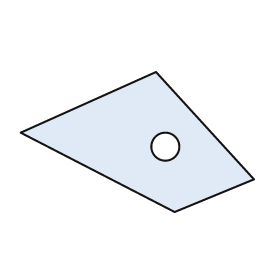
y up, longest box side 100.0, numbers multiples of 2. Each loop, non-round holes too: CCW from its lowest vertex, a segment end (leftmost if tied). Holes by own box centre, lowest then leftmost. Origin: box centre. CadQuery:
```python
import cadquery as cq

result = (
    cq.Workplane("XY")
    .moveTo(16.0, -30.0)
    .lineTo(50.0, -16.0)
    .lineTo(8.0, 30.0)
    .lineTo(-50.0, 4.0)
    .close()
    .moveTo(12.0, -2.0)
    .circle(6.0)
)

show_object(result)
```